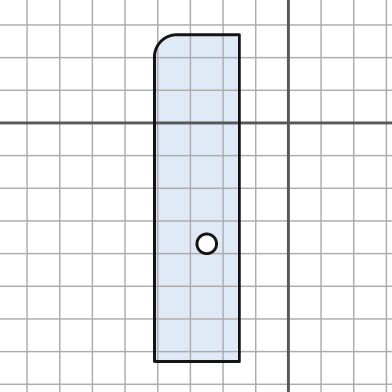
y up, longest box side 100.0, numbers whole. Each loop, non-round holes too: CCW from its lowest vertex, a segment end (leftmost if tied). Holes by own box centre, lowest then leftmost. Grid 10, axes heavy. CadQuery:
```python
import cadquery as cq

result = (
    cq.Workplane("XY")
    .moveTo(-41.0, -73.0)
    .lineTo(-15.0, -73.0)
    .lineTo(-15.0, 27.0)
    .lineTo(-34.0, 27.0)
    .threePointArc((-39.0, 25.0), (-41.0, 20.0))
    .close()
    .moveTo(-25.0, -37.0)
    .circle(3.0)
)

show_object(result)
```